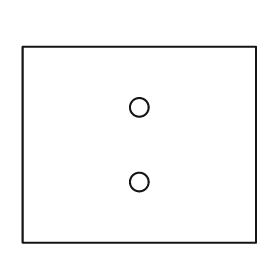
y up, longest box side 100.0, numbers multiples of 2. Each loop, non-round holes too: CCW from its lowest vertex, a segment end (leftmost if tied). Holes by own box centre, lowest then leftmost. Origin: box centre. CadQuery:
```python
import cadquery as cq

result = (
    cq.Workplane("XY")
    .moveTo(-50.0, -42.0)
    .lineTo(50.0, -42.0)
    .lineTo(50.0, 42.0)
    .lineTo(-50.0, 42.0)
    .close()
    .moveTo(0.0, -16.0)
    .circle(4.0)
    .moveTo(0.0, 16.0)
    .circle(4.0)
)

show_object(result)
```